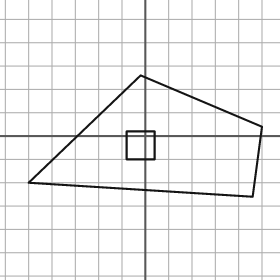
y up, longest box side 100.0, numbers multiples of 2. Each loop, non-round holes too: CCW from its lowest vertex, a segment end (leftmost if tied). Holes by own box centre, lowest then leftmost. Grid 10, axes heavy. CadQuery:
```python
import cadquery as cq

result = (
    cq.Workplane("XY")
    .moveTo(46.0, -26.0)
    .lineTo(50.0, 4.0)
    .lineTo(-2.0, 26.0)
    .lineTo(-50.0, -20.0)
    .close()
    .moveTo(-8.0, -10.0)
    .lineTo(4.0, -10.0)
    .lineTo(4.0, 2.0)
    .lineTo(-8.0, 2.0)
    .close()
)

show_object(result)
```